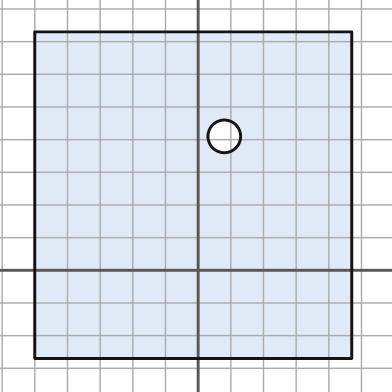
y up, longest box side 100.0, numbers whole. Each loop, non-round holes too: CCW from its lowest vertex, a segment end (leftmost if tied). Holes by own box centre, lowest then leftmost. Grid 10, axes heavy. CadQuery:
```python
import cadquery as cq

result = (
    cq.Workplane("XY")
    .moveTo(-50.0, -27.0)
    .lineTo(47.0, -27.0)
    .lineTo(47.0, 73.0)
    .lineTo(-50.0, 73.0)
    .close()
    .moveTo(8.0, 41.0)
    .circle(5.0)
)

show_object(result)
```